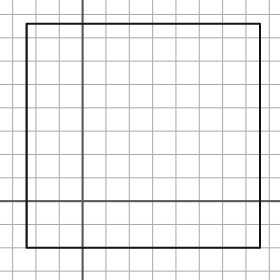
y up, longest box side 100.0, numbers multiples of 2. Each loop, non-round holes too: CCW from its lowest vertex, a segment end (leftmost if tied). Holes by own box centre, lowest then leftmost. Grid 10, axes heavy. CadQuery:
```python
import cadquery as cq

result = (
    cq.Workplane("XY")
    .moveTo(-24.0, -20.0)
    .lineTo(76.0, -20.0)
    .lineTo(76.0, 76.0)
    .lineTo(-24.0, 76.0)
    .close()
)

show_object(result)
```